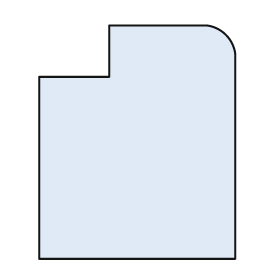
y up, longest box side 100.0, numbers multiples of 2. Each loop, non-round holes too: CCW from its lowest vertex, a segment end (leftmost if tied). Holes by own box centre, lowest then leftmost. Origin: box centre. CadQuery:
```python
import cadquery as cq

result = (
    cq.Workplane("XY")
    .moveTo(-42.0, -50.0)
    .lineTo(42.0, -50.0)
    .lineTo(42.0, 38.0)
    .threePointArc((38.0, 46.0), (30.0, 50.0))
    .lineTo(-12.0, 50.0)
    .lineTo(-12.0, 28.0)
    .lineTo(-42.0, 28.0)
    .close()
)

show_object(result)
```